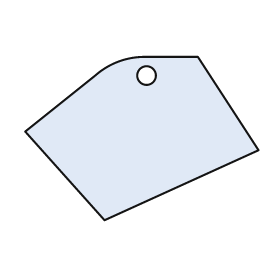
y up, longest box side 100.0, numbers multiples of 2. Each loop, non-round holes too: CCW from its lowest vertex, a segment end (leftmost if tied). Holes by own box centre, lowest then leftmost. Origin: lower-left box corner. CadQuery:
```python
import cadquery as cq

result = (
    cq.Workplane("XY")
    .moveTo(34.0, 0.0)
    .lineTo(100.0, 30.0)
    .lineTo(74.0, 70.0)
    .lineTo(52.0, 70.0)
    .threePointArc((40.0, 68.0), (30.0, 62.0))
    .lineTo(0.0, 38.0)
    .close()
    .moveTo(52.0, 62.0)
    .circle(4.0)
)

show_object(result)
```